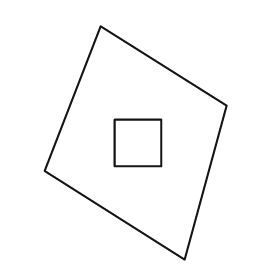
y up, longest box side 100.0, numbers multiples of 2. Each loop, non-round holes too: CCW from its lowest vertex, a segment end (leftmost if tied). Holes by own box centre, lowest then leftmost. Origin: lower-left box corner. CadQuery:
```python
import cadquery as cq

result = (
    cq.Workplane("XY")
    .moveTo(60.0, 0.0)
    .lineTo(78.0, 66.0)
    .lineTo(24.0, 100.0)
    .lineTo(0.0, 38.0)
    .close()
    .moveTo(30.0, 40.0)
    .lineTo(50.0, 40.0)
    .lineTo(50.0, 60.0)
    .lineTo(30.0, 60.0)
    .close()
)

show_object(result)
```